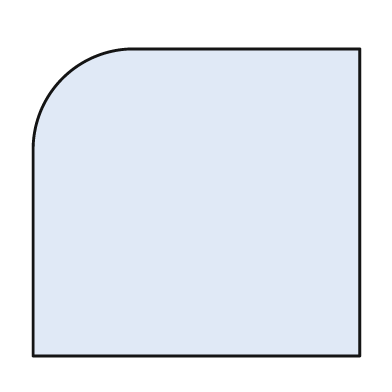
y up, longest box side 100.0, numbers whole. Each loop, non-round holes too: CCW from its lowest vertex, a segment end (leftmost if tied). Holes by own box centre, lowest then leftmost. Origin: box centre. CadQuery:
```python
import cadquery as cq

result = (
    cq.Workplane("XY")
    .moveTo(-50.0, -47.0)
    .lineTo(50.0, -47.0)
    .lineTo(50.0, 47.0)
    .lineTo(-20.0, 47.0)
    .threePointArc((-41.0, 38.0), (-50.0, 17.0))
    .close()
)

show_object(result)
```